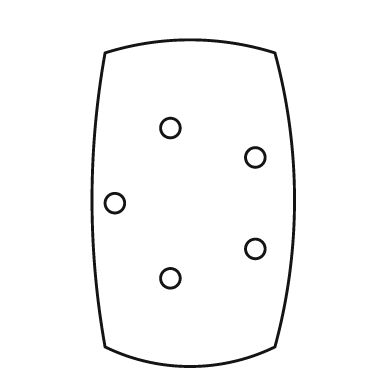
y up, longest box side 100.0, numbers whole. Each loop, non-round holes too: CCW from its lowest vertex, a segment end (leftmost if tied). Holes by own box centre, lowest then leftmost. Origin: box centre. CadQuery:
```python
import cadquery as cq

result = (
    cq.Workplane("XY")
    .moveTo(-27.0, -44.0)
    .threePointArc((-1.0, -50.0), (25.0, -44.0))
    .threePointArc((31.0, 1.0), (25.0, 46.0))
    .threePointArc((-1.0, 50.0), (-27.0, 46.0))
    .threePointArc((-31.0, 1.0), (-27.0, -44.0))
    .close()
    .moveTo(-7.0, -23.0)
    .circle(3.0)
    .moveTo(19.0, -14.0)
    .circle(3.0)
    .moveTo(-24.0, 0.0)
    .circle(3.0)
    .moveTo(19.0, 14.0)
    .circle(3.0)
    .moveTo(-7.0, 23.0)
    .circle(3.0)
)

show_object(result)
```